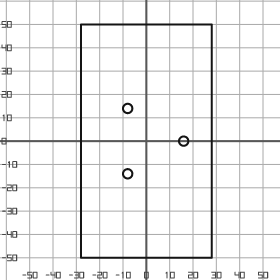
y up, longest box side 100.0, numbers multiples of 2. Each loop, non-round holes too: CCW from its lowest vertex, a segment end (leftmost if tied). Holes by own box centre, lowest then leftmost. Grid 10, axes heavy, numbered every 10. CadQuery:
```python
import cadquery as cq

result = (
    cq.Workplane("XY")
    .moveTo(-28.0, -50.0)
    .lineTo(28.0, -50.0)
    .lineTo(28.0, 50.0)
    .lineTo(-28.0, 50.0)
    .close()
    .moveTo(-8.0, -14.0)
    .circle(2.0)
    .moveTo(16.0, 0.0)
    .circle(2.0)
    .moveTo(-8.0, 14.0)
    .circle(2.0)
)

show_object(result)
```